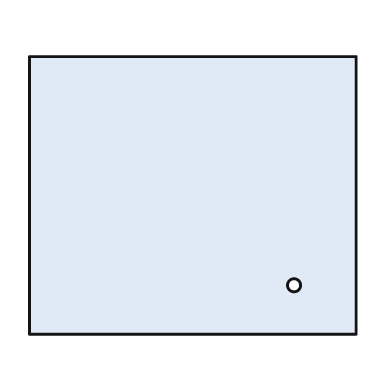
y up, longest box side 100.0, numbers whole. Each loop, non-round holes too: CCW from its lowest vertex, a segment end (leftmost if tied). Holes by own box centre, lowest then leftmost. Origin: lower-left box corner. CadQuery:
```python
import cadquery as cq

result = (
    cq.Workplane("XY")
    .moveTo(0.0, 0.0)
    .lineTo(100.0, 0.0)
    .lineTo(100.0, 85.0)
    .lineTo(0.0, 85.0)
    .close()
    .moveTo(81.0, 15.0)
    .circle(2.0)
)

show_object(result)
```